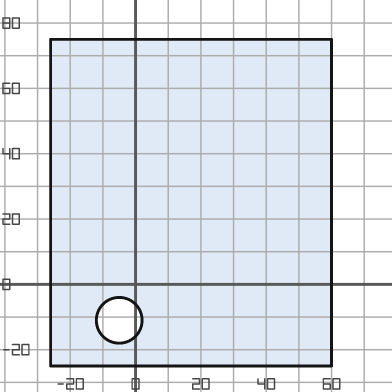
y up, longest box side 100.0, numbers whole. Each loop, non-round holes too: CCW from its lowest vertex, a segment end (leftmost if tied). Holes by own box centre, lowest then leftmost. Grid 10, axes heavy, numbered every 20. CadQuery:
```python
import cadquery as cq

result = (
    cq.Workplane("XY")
    .moveTo(-26.0, -25.0)
    .lineTo(60.0, -25.0)
    .lineTo(60.0, 75.0)
    .lineTo(-26.0, 75.0)
    .close()
    .moveTo(-5.0, -11.0)
    .circle(7.0)
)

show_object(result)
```